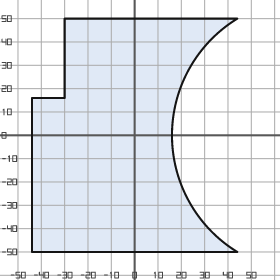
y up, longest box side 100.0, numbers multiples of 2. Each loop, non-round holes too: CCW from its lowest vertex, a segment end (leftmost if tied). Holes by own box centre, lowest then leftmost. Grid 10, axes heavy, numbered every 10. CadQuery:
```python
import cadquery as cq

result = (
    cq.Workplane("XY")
    .moveTo(-44.0, -50.0)
    .lineTo(44.0, -50.0)
    .threePointArc((16.0, 0.0), (44.0, 50.0))
    .lineTo(-30.0, 50.0)
    .lineTo(-30.0, 16.0)
    .lineTo(-44.0, 16.0)
    .close()
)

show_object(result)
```